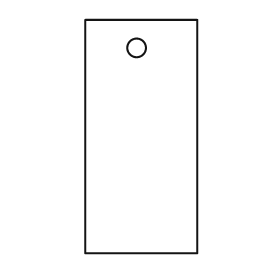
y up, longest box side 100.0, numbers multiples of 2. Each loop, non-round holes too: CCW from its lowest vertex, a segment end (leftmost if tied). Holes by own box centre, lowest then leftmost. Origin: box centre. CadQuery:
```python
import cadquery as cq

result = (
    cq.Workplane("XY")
    .moveTo(-24.0, -50.0)
    .lineTo(24.0, -50.0)
    .lineTo(24.0, 50.0)
    .lineTo(-24.0, 50.0)
    .close()
    .moveTo(-2.0, 38.0)
    .circle(4.0)
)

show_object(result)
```